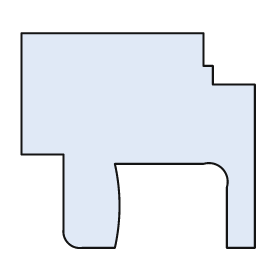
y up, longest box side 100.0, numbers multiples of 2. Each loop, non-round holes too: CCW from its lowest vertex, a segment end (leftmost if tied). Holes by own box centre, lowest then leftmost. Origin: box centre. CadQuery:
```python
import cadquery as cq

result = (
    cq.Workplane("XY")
    .moveTo(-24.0, -46.0)
    .lineTo(-10.0, -46.0)
    .threePointArc((-8.0, -28.0), (-10.0, -10.0))
    .lineTo(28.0, -10.0)
    .threePointArc((36.0, -12.0), (38.0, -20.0))
    .lineTo(38.0, -46.0)
    .lineTo(50.0, -46.0)
    .lineTo(50.0, 24.0)
    .lineTo(32.0, 24.0)
    .lineTo(32.0, 32.0)
    .lineTo(28.0, 32.0)
    .lineTo(28.0, 46.0)
    .lineTo(-50.0, 46.0)
    .lineTo(-50.0, -6.0)
    .lineTo(-32.0, -6.0)
    .lineTo(-32.0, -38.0)
    .threePointArc((-30.0, -44.0), (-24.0, -46.0))
    .close()
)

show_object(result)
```